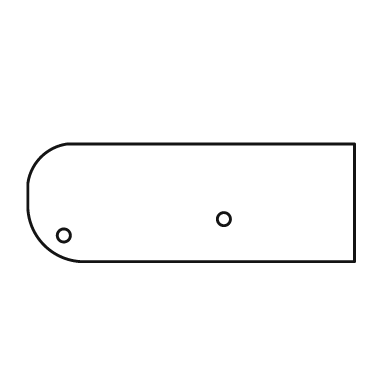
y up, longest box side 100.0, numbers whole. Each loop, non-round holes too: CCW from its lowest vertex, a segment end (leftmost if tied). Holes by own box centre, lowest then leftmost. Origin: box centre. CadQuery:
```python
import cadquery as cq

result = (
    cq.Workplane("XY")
    .moveTo(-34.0, -18.0)
    .lineTo(50.0, -18.0)
    .lineTo(50.0, 18.0)
    .lineTo(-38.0, 18.0)
    .threePointArc((-46.0, 14.0), (-50.0, 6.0))
    .lineTo(-50.0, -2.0)
    .threePointArc((-45.0, -13.0), (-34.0, -18.0))
    .close()
    .moveTo(-39.0, -10.0)
    .circle(2.0)
    .moveTo(10.0, -5.0)
    .circle(2.0)
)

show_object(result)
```